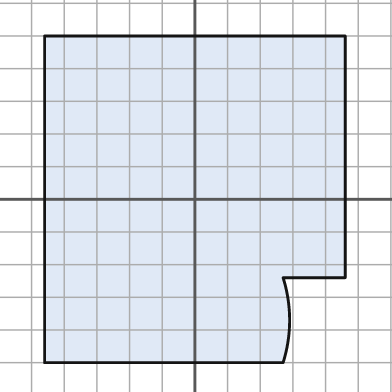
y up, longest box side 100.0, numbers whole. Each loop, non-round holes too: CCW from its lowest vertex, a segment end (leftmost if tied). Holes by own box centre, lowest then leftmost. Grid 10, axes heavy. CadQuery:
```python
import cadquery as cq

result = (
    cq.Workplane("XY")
    .moveTo(-46.0, -50.0)
    .lineTo(27.0, -50.0)
    .threePointArc((29.0, -37.0), (27.0, -24.0))
    .lineTo(46.0, -24.0)
    .lineTo(46.0, 50.0)
    .lineTo(-46.0, 50.0)
    .close()
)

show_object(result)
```